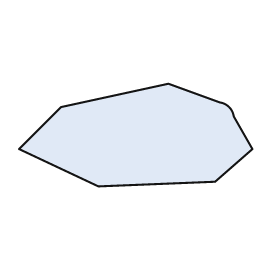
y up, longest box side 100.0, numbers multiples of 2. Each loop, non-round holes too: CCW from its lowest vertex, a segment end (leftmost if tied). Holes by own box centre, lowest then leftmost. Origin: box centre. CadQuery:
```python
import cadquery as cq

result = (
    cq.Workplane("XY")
    .moveTo(-16.0, -22.0)
    .lineTo(34.0, -20.0)
    .lineTo(50.0, -6.0)
    .lineTo(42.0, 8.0)
    .threePointArc((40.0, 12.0), (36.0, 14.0))
    .lineTo(14.0, 22.0)
    .lineTo(-32.0, 12.0)
    .lineTo(-50.0, -6.0)
    .close()
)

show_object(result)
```